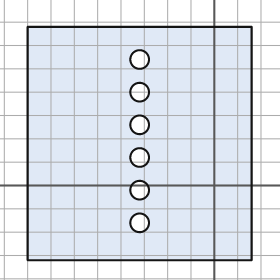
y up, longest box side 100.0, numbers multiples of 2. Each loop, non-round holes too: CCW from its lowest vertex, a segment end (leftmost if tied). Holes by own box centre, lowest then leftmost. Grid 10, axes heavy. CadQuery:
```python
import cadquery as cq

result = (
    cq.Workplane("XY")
    .moveTo(-80.0, -32.0)
    .lineTo(16.0, -32.0)
    .lineTo(16.0, 68.0)
    .lineTo(-80.0, 68.0)
    .close()
    .moveTo(-32.0, -16.0)
    .circle(4.0)
    .moveTo(-32.0, -2.0)
    .circle(4.0)
    .moveTo(-32.0, 12.0)
    .circle(4.0)
    .moveTo(-32.0, 26.0)
    .circle(4.0)
    .moveTo(-32.0, 40.0)
    .circle(4.0)
    .moveTo(-32.0, 54.0)
    .circle(4.0)
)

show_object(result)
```